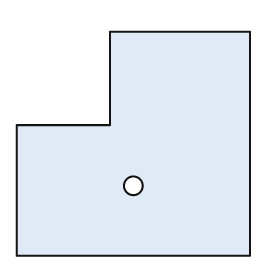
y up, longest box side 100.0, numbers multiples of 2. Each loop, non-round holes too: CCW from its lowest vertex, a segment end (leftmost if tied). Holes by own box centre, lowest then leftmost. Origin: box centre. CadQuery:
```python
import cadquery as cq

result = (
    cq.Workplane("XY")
    .moveTo(-50.0, -48.0)
    .lineTo(50.0, -48.0)
    .lineTo(50.0, 48.0)
    .lineTo(-10.0, 48.0)
    .lineTo(-10.0, 8.0)
    .lineTo(-50.0, 8.0)
    .close()
    .moveTo(0.0, -18.0)
    .circle(4.0)
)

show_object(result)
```